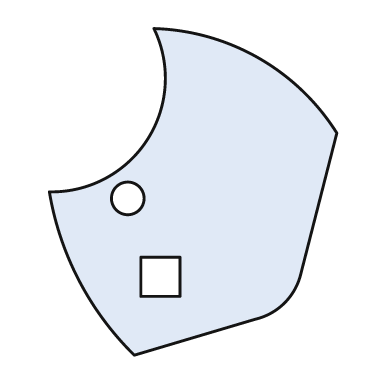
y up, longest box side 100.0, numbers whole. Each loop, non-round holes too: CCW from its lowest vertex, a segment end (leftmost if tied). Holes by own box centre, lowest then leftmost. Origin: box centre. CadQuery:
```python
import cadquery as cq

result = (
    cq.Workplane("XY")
    .moveTo(-18.0, -50.0)
    .lineTo(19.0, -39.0)
    .threePointArc((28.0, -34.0), (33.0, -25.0))
    .lineTo(44.0, 18.0)
    .threePointArc((20.0, 41.0), (-12.0, 50.0))
    .threePointArc((-14.0, 16.0), (-44.0, 0.0))
    .threePointArc((-35.0, -27.0), (-18.0, -50.0))
    .close()
    .moveTo(-16.0, -32.0)
    .lineTo(-4.0, -32.0)
    .lineTo(-4.0, -20.0)
    .lineTo(-16.0, -20.0)
    .close()
    .moveTo(-20.0, -2.0)
    .circle(5.0)
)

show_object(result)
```